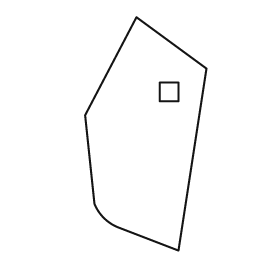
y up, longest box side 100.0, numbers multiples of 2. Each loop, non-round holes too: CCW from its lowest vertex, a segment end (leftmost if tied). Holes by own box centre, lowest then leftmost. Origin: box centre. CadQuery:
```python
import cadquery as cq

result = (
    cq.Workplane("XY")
    .moveTo(14.0, -50.0)
    .lineTo(26.0, 28.0)
    .lineTo(-4.0, 50.0)
    .lineTo(-26.0, 8.0)
    .lineTo(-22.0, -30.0)
    .threePointArc((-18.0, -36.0), (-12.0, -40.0))
    .close()
    .moveTo(6.0, 14.0)
    .lineTo(14.0, 14.0)
    .lineTo(14.0, 22.0)
    .lineTo(6.0, 22.0)
    .close()
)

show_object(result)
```